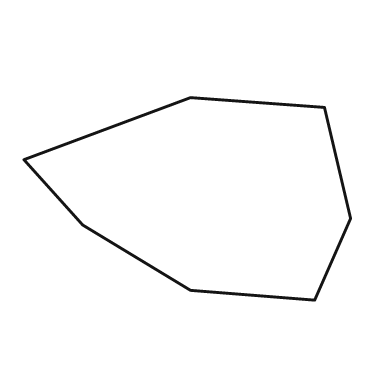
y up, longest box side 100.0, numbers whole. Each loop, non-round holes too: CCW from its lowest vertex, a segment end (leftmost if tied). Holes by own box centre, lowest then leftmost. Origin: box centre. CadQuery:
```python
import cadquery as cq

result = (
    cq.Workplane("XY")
    .moveTo(39.0, -31.0)
    .lineTo(50.0, -6.0)
    .lineTo(42.0, 28.0)
    .lineTo(1.0, 31.0)
    .lineTo(-50.0, 12.0)
    .lineTo(-32.0, -8.0)
    .lineTo(1.0, -28.0)
    .close()
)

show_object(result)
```